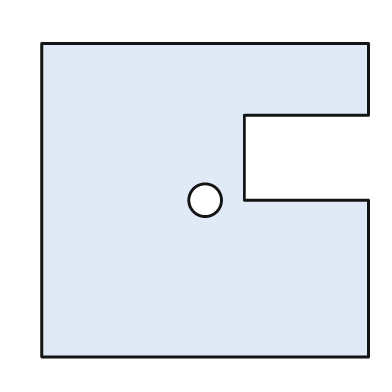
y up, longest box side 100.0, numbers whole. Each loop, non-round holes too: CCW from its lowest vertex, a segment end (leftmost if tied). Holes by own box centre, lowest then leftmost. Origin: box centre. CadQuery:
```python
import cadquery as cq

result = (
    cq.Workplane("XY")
    .moveTo(-50.0, -48.0)
    .lineTo(50.0, -48.0)
    .lineTo(50.0, 0.0)
    .lineTo(12.0, 0.0)
    .lineTo(12.0, 26.0)
    .lineTo(50.0, 26.0)
    .lineTo(50.0, 48.0)
    .lineTo(-50.0, 48.0)
    .close()
    .moveTo(0.0, 0.0)
    .circle(5.0)
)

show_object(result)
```